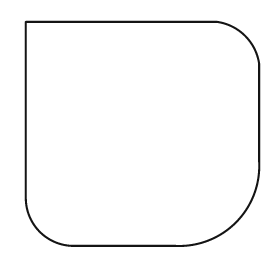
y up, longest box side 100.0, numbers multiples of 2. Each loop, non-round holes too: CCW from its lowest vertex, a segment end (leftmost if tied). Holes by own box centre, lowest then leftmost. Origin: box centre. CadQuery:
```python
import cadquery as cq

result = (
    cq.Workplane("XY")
    .moveTo(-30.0, -48.0)
    .lineTo(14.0, -48.0)
    .threePointArc((40.0, -38.0), (50.0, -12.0))
    .lineTo(50.0, 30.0)
    .threePointArc((44.0, 42.0), (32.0, 48.0))
    .lineTo(-50.0, 48.0)
    .lineTo(-50.0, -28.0)
    .threePointArc((-44.0, -42.0), (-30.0, -48.0))
    .close()
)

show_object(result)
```